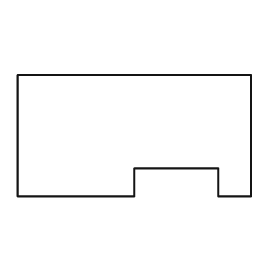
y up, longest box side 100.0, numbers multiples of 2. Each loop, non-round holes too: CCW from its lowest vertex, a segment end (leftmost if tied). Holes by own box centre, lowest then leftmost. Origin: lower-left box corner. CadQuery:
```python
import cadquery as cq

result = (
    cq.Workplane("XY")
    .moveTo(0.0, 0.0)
    .lineTo(50.0, 0.0)
    .lineTo(50.0, 12.0)
    .lineTo(86.0, 12.0)
    .lineTo(86.0, 0.0)
    .lineTo(100.0, 0.0)
    .lineTo(100.0, 52.0)
    .lineTo(0.0, 52.0)
    .close()
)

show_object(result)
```